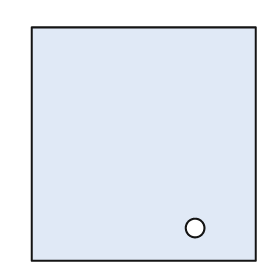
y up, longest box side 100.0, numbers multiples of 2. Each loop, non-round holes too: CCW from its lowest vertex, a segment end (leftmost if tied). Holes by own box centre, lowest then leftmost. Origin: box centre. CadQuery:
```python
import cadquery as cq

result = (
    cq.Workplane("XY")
    .moveTo(-48.0, -50.0)
    .lineTo(48.0, -50.0)
    .lineTo(48.0, 50.0)
    .lineTo(-48.0, 50.0)
    .close()
    .moveTo(22.0, -36.0)
    .circle(4.0)
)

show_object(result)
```